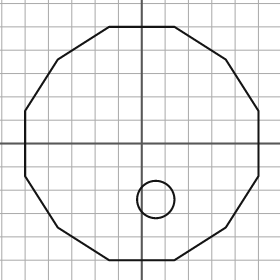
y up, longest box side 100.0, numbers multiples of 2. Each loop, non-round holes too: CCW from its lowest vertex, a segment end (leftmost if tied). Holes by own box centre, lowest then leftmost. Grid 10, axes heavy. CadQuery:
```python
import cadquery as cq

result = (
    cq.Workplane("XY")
    .moveTo(-14.0, -50.0)
    .lineTo(14.0, -50.0)
    .lineTo(36.0, -36.0)
    .lineTo(50.0, -14.0)
    .lineTo(50.0, 14.0)
    .lineTo(36.0, 36.0)
    .lineTo(14.0, 50.0)
    .lineTo(-14.0, 50.0)
    .lineTo(-36.0, 36.0)
    .lineTo(-50.0, 14.0)
    .lineTo(-50.0, -14.0)
    .lineTo(-36.0, -36.0)
    .close()
    .moveTo(6.0, -24.0)
    .circle(8.0)
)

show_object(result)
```